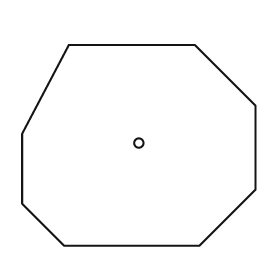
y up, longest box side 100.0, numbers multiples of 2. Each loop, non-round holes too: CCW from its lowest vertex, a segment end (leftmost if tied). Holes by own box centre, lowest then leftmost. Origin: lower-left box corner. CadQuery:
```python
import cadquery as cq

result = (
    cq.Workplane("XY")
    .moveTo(18.0, 0.0)
    .lineTo(76.0, 0.0)
    .lineTo(100.0, 24.0)
    .lineTo(100.0, 60.0)
    .lineTo(74.0, 86.0)
    .lineTo(20.0, 86.0)
    .lineTo(0.0, 48.0)
    .lineTo(0.0, 18.0)
    .close()
    .moveTo(50.0, 44.0)
    .circle(2.0)
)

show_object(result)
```